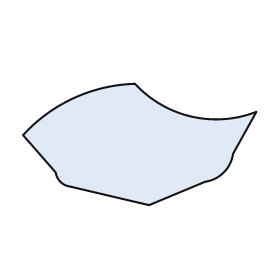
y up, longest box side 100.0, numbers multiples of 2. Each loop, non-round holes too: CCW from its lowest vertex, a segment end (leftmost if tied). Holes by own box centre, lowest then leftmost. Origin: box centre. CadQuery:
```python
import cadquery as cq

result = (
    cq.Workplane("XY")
    .moveTo(4.0, -26.0)
    .lineTo(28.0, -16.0)
    .threePointArc((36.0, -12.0), (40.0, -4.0))
    .lineTo(50.0, 14.0)
    .threePointArc((22.0, 12.0), (-2.0, 26.0))
    .threePointArc((-28.0, 20.0), (-50.0, 4.0))
    .lineTo(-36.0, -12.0)
    .threePointArc((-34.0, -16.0), (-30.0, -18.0))
    .close()
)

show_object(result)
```